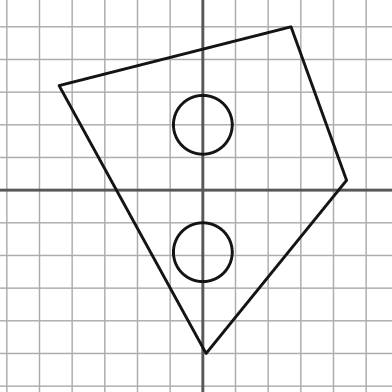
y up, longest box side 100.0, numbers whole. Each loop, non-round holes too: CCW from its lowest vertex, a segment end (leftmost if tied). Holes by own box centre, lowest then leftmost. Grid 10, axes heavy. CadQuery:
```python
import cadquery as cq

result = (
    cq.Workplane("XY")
    .moveTo(1.0, -50.0)
    .lineTo(44.0, 3.0)
    .lineTo(27.0, 50.0)
    .lineTo(-44.0, 32.0)
    .close()
    .moveTo(0.0, -19.0)
    .circle(9.0)
    .moveTo(0.0, 20.0)
    .circle(9.0)
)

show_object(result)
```